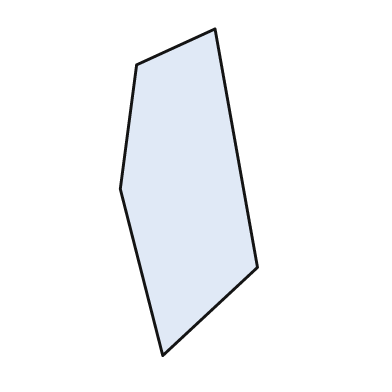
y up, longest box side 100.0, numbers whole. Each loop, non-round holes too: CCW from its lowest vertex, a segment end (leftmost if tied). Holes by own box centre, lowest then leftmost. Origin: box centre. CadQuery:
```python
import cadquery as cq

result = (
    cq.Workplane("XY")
    .moveTo(-8.0, -50.0)
    .lineTo(21.0, -23.0)
    .lineTo(8.0, 50.0)
    .lineTo(-16.0, 39.0)
    .lineTo(-21.0, 1.0)
    .close()
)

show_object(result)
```